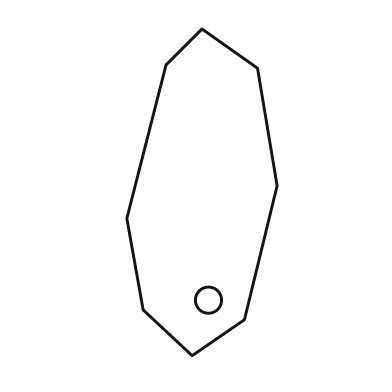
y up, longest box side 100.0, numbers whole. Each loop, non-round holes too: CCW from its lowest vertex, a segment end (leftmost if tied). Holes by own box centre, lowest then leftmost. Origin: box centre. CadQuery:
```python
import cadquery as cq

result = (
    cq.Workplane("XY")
    .moveTo(-3.0, -50.0)
    .lineTo(13.0, -39.0)
    .lineTo(23.0, 2.0)
    .lineTo(17.0, 38.0)
    .lineTo(0.0, 50.0)
    .lineTo(-11.0, 39.0)
    .lineTo(-23.0, -8.0)
    .lineTo(-18.0, -36.0)
    .close()
    .moveTo(2.0, -33.0)
    .circle(4.0)
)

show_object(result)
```